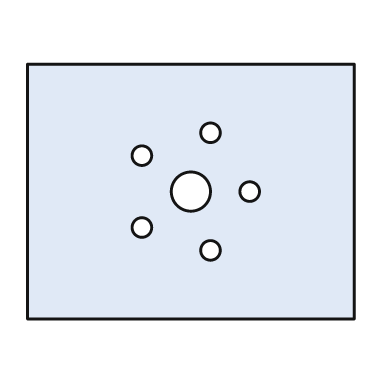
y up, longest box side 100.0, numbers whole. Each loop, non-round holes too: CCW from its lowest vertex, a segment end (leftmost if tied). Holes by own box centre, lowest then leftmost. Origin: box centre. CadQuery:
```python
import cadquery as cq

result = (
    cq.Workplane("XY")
    .moveTo(-50.0, -39.0)
    .lineTo(50.0, -39.0)
    .lineTo(50.0, 39.0)
    .lineTo(-50.0, 39.0)
    .close()
    .moveTo(6.0, -18.0)
    .circle(3.0)
    .moveTo(-15.0, -11.0)
    .circle(3.0)
    .moveTo(0.0, 0.0)
    .circle(6.0)
    .moveTo(18.0, 0.0)
    .circle(3.0)
    .moveTo(-15.0, 11.0)
    .circle(3.0)
    .moveTo(6.0, 18.0)
    .circle(3.0)
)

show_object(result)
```